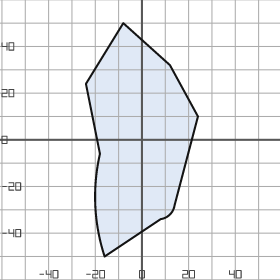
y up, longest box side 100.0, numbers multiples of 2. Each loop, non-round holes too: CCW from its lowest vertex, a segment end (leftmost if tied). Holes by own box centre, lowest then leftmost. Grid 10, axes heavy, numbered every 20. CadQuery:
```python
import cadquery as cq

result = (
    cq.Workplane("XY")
    .moveTo(-16.0, -50.0)
    .lineTo(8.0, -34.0)
    .threePointArc((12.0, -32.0), (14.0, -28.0))
    .lineTo(24.0, 10.0)
    .lineTo(12.0, 32.0)
    .lineTo(-8.0, 50.0)
    .lineTo(-24.0, 24.0)
    .lineTo(-18.0, -6.0)
    .threePointArc((-20.0, -28.0), (-16.0, -50.0))
    .close()
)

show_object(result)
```